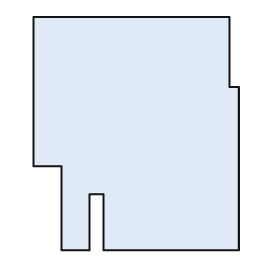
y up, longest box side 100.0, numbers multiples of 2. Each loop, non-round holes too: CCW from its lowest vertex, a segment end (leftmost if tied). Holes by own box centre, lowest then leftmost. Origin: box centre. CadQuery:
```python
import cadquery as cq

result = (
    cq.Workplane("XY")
    .moveTo(-32.0, -50.0)
    .lineTo(-20.0, -50.0)
    .lineTo(-20.0, -26.0)
    .lineTo(-14.0, -26.0)
    .lineTo(-14.0, -50.0)
    .lineTo(44.0, -50.0)
    .lineTo(44.0, 20.0)
    .lineTo(40.0, 20.0)
    .lineTo(40.0, 50.0)
    .lineTo(-44.0, 50.0)
    .lineTo(-44.0, -14.0)
    .lineTo(-32.0, -14.0)
    .close()
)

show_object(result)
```